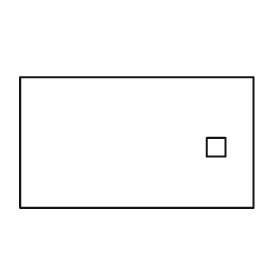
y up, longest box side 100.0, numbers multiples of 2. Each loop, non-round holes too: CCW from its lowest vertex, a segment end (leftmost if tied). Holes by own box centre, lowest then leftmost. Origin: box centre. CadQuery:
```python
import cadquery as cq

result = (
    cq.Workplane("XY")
    .moveTo(-50.0, -28.0)
    .lineTo(50.0, -28.0)
    .lineTo(50.0, 28.0)
    .lineTo(-50.0, 28.0)
    .close()
    .moveTo(30.0, -6.0)
    .lineTo(38.0, -6.0)
    .lineTo(38.0, 2.0)
    .lineTo(30.0, 2.0)
    .close()
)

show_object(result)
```